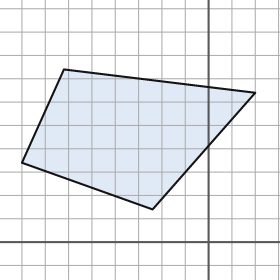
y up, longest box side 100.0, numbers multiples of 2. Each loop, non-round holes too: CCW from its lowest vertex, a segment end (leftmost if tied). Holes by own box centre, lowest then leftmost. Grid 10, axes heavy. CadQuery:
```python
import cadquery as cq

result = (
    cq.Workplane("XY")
    .moveTo(-24.0, 14.0)
    .lineTo(20.0, 64.0)
    .lineTo(-62.0, 74.0)
    .lineTo(-80.0, 34.0)
    .close()
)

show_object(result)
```